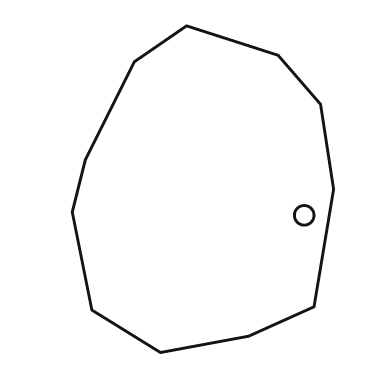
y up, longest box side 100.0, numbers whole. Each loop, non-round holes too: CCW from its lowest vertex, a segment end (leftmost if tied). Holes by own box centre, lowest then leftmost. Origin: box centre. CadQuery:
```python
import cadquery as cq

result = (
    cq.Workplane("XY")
    .moveTo(-13.0, -50.0)
    .lineTo(14.0, -45.0)
    .lineTo(34.0, -36.0)
    .lineTo(40.0, 0.0)
    .lineTo(36.0, 26.0)
    .lineTo(23.0, 41.0)
    .lineTo(-5.0, 50.0)
    .lineTo(-21.0, 39.0)
    .lineTo(-36.0, 9.0)
    .lineTo(-40.0, -7.0)
    .lineTo(-34.0, -37.0)
    .close()
    .moveTo(31.0, -8.0)
    .circle(3.0)
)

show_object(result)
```